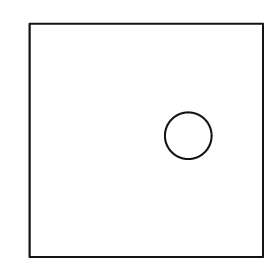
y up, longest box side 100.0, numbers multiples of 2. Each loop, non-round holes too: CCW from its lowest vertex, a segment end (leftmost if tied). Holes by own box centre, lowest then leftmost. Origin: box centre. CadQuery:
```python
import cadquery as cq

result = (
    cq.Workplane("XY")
    .moveTo(-50.0, -50.0)
    .lineTo(50.0, -50.0)
    .lineTo(50.0, 50.0)
    .lineTo(-50.0, 50.0)
    .close()
    .moveTo(18.0, 2.0)
    .circle(10.0)
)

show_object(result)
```